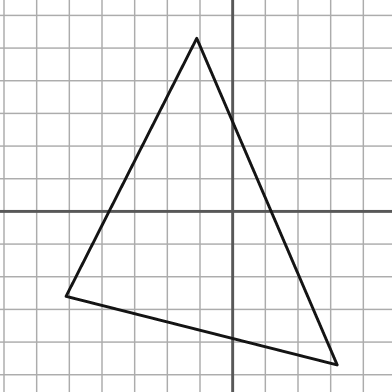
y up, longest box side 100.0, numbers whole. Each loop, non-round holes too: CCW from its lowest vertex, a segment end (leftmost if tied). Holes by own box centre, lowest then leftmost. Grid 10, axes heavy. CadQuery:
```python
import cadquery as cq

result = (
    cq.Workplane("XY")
    .moveTo(32.0, -47.0)
    .lineTo(-11.0, 53.0)
    .lineTo(-51.0, -26.0)
    .close()
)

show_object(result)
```